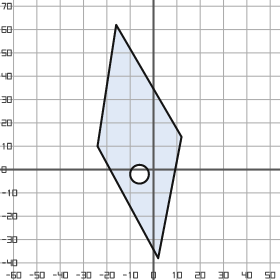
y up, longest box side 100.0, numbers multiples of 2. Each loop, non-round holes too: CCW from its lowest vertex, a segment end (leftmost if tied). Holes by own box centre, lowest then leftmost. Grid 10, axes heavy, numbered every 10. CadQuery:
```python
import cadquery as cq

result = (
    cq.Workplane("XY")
    .moveTo(2.0, -38.0)
    .lineTo(12.0, 14.0)
    .lineTo(-16.0, 62.0)
    .lineTo(-24.0, 10.0)
    .close()
    .moveTo(-6.0, -2.0)
    .circle(4.0)
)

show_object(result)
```